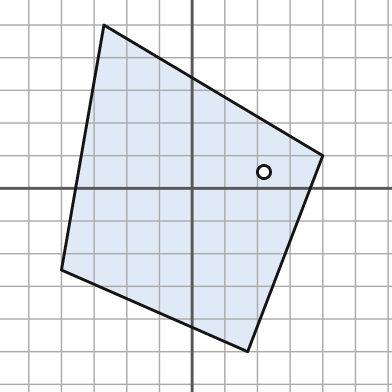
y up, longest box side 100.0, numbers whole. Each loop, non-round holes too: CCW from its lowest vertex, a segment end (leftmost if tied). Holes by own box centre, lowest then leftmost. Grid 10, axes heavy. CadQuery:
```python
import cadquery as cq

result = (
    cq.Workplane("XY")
    .moveTo(17.0, -50.0)
    .lineTo(40.0, 10.0)
    .lineTo(-27.0, 50.0)
    .lineTo(-40.0, -25.0)
    .close()
    .moveTo(22.0, 5.0)
    .circle(2.0)
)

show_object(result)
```